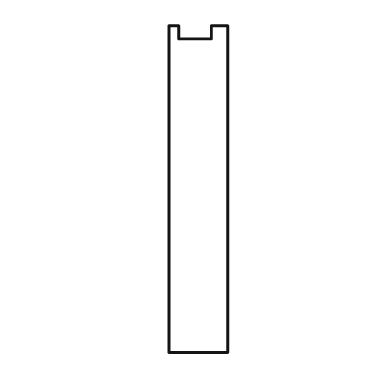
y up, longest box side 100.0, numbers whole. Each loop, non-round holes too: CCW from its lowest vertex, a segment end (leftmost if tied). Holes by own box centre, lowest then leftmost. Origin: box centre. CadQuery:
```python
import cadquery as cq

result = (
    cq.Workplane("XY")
    .moveTo(-9.0, -50.0)
    .lineTo(9.0, -50.0)
    .lineTo(9.0, 50.0)
    .lineTo(4.0, 50.0)
    .lineTo(4.0, 46.0)
    .lineTo(-6.0, 46.0)
    .lineTo(-6.0, 50.0)
    .lineTo(-9.0, 50.0)
    .close()
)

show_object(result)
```